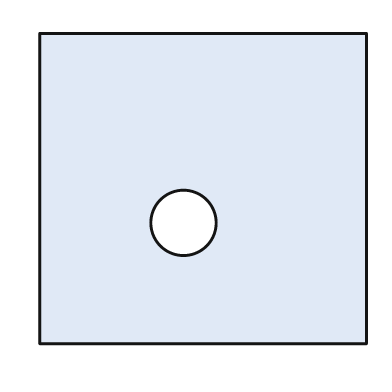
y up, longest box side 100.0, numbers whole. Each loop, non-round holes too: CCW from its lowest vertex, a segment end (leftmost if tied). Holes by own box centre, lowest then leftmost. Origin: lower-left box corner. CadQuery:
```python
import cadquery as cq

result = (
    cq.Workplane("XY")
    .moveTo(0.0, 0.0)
    .lineTo(100.0, 0.0)
    .lineTo(100.0, 95.0)
    .lineTo(0.0, 95.0)
    .close()
    .moveTo(44.0, 37.0)
    .circle(10.0)
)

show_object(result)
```